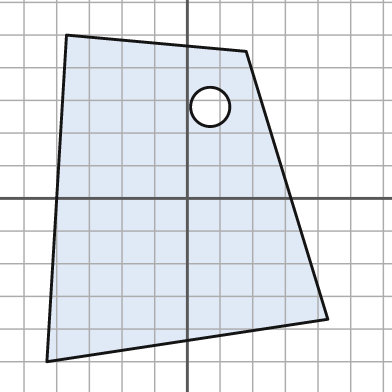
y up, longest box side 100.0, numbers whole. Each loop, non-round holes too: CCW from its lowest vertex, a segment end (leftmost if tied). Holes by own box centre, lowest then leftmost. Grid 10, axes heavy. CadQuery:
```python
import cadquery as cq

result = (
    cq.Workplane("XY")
    .moveTo(-43.0, -50.0)
    .lineTo(43.0, -37.0)
    .lineTo(18.0, 45.0)
    .lineTo(-37.0, 50.0)
    .close()
    .moveTo(7.0, 28.0)
    .circle(6.0)
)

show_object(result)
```